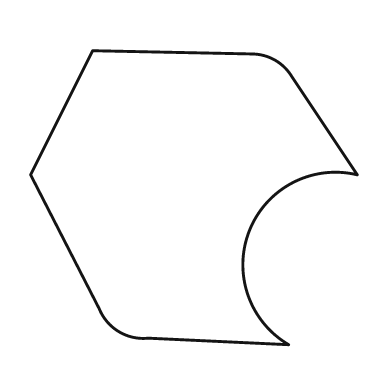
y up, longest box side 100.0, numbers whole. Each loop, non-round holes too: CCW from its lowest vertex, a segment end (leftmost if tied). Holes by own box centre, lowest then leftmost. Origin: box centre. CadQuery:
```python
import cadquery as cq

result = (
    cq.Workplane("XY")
    .moveTo(29.0, -45.0)
    .threePointArc((17.0, -10.0), (50.0, 7.0))
    .lineTo(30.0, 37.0)
    .threePointArc((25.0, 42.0), (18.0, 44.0))
    .lineTo(-31.0, 45.0)
    .lineTo(-50.0, 7.0)
    .lineTo(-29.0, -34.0)
    .threePointArc((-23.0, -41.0), (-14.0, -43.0))
    .close()
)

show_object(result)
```